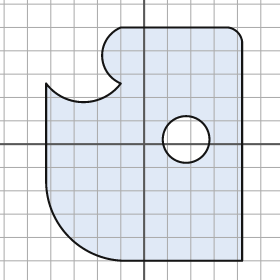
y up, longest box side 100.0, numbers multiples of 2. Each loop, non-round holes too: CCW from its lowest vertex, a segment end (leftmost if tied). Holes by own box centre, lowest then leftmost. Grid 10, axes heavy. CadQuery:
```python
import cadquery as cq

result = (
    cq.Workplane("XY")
    .moveTo(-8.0, -50.0)
    .lineTo(42.0, -50.0)
    .lineTo(42.0, 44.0)
    .threePointArc((40.0, 48.0), (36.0, 50.0))
    .lineTo(-10.0, 50.0)
    .threePointArc((-18.0, 38.0), (-10.0, 26.0))
    .threePointArc((-26.0, 18.0), (-42.0, 26.0))
    .lineTo(-42.0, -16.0)
    .threePointArc((-32.0, -40.0), (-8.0, -50.0))
    .close()
    .moveTo(18.0, 2.0)
    .circle(10.0)
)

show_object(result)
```